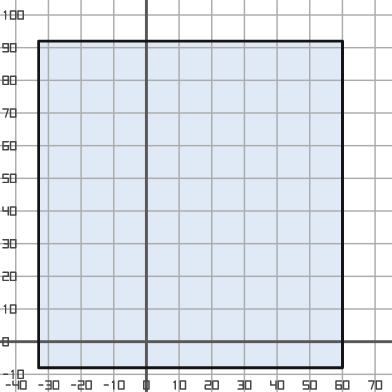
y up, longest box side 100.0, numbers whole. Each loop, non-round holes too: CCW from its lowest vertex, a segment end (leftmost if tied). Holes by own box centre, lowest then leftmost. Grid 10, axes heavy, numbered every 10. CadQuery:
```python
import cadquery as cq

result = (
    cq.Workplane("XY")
    .moveTo(-33.0, -8.0)
    .lineTo(60.0, -8.0)
    .lineTo(60.0, 92.0)
    .lineTo(-33.0, 92.0)
    .close()
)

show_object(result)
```